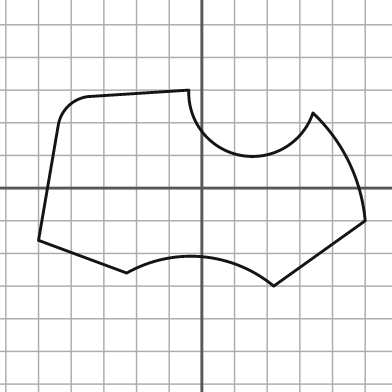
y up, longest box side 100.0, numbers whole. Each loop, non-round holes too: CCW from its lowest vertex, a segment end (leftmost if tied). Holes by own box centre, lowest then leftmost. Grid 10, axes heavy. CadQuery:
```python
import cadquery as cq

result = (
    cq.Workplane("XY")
    .moveTo(22.0, -30.0)
    .lineTo(50.0, -10.0)
    .threePointArc((45.0, 8.0), (34.0, 23.0))
    .threePointArc((12.0, 10.0), (-4.0, 30.0))
    .lineTo(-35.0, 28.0)
    .threePointArc((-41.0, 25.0), (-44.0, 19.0))
    .lineTo(-50.0, -16.0)
    .lineTo(-23.0, -26.0)
    .threePointArc((0.0, -21.0), (22.0, -30.0))
    .close()
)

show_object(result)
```